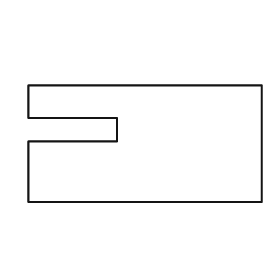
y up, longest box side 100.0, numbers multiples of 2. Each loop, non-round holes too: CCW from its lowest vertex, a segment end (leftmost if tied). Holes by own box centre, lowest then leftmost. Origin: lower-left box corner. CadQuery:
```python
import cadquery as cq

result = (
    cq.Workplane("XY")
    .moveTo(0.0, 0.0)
    .lineTo(100.0, 0.0)
    .lineTo(100.0, 50.0)
    .lineTo(0.0, 50.0)
    .lineTo(0.0, 36.0)
    .lineTo(38.0, 36.0)
    .lineTo(38.0, 26.0)
    .lineTo(0.0, 26.0)
    .close()
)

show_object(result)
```